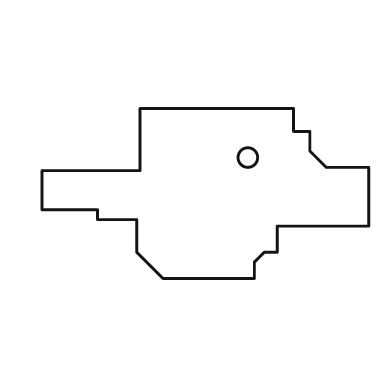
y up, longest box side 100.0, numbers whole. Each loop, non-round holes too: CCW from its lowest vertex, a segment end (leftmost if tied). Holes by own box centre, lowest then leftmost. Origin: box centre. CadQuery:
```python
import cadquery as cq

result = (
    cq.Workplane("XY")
    .moveTo(-13.0, -26.0)
    .lineTo(15.0, -26.0)
    .lineTo(15.0, -21.0)
    .lineTo(18.0, -18.0)
    .lineTo(22.0, -18.0)
    .lineTo(22.0, -10.0)
    .lineTo(50.0, -10.0)
    .lineTo(50.0, 8.0)
    .lineTo(37.0, 8.0)
    .lineTo(32.0, 13.0)
    .lineTo(32.0, 19.0)
    .lineTo(27.0, 19.0)
    .lineTo(27.0, 26.0)
    .lineTo(-20.0, 26.0)
    .lineTo(-20.0, 7.0)
    .lineTo(-50.0, 7.0)
    .lineTo(-50.0, -5.0)
    .lineTo(-33.0, -5.0)
    .lineTo(-33.0, -8.0)
    .lineTo(-21.0, -8.0)
    .lineTo(-21.0, -18.0)
    .close()
    .moveTo(13.0, 11.0)
    .circle(3.0)
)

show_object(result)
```